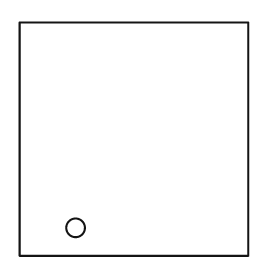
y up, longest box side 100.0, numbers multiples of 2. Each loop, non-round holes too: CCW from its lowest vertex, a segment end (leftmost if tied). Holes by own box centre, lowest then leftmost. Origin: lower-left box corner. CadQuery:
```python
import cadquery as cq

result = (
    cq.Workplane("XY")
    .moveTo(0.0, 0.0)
    .lineTo(98.0, 0.0)
    .lineTo(98.0, 100.0)
    .lineTo(0.0, 100.0)
    .close()
    .moveTo(24.0, 12.0)
    .circle(4.0)
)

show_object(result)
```